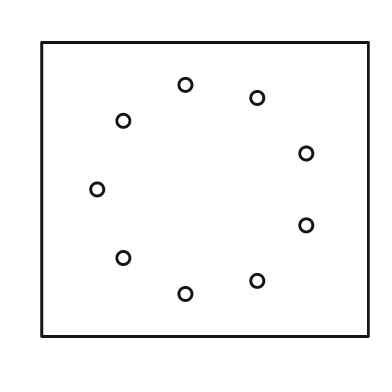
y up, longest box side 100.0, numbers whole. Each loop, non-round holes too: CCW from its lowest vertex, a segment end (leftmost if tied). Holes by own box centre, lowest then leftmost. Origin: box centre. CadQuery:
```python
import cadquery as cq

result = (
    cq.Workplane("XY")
    .moveTo(-50.0, -45.0)
    .lineTo(50.0, -45.0)
    .lineTo(50.0, 45.0)
    .lineTo(-50.0, 45.0)
    .close()
    .moveTo(-6.0, -32.0)
    .circle(2.0)
    .moveTo(16.0, -28.0)
    .circle(2.0)
    .moveTo(-25.0, -21.0)
    .circle(2.0)
    .moveTo(31.0, -11.0)
    .circle(2.0)
    .moveTo(-33.0, 0.0)
    .circle(2.0)
    .moveTo(31.0, 11.0)
    .circle(2.0)
    .moveTo(-25.0, 21.0)
    .circle(2.0)
    .moveTo(16.0, 28.0)
    .circle(2.0)
    .moveTo(-6.0, 32.0)
    .circle(2.0)
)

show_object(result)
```